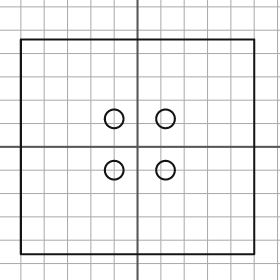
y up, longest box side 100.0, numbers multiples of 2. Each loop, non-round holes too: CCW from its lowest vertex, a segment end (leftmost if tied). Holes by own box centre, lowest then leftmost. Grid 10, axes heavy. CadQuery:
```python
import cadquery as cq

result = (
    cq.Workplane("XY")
    .moveTo(-50.0, -46.0)
    .lineTo(50.0, -46.0)
    .lineTo(50.0, 46.0)
    .lineTo(-50.0, 46.0)
    .close()
    .moveTo(-10.0, -10.0)
    .circle(4.0)
    .moveTo(12.0, -10.0)
    .circle(4.0)
    .moveTo(-10.0, 12.0)
    .circle(4.0)
    .moveTo(12.0, 12.0)
    .circle(4.0)
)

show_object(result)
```